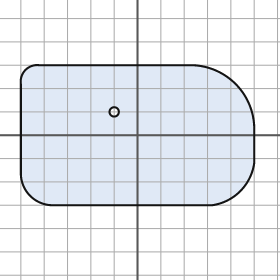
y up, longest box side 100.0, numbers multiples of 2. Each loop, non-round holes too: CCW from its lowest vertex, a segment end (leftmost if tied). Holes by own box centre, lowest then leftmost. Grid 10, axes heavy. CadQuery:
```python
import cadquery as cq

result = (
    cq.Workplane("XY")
    .moveTo(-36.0, -30.0)
    .lineTo(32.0, -30.0)
    .threePointArc((44.0, -24.0), (50.0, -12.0))
    .lineTo(50.0, 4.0)
    .threePointArc((42.0, 22.0), (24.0, 30.0))
    .lineTo(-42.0, 30.0)
    .threePointArc((-48.0, 28.0), (-50.0, 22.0))
    .lineTo(-50.0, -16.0)
    .threePointArc((-46.0, -26.0), (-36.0, -30.0))
    .close()
    .moveTo(-10.0, 10.0)
    .circle(2.0)
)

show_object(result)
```